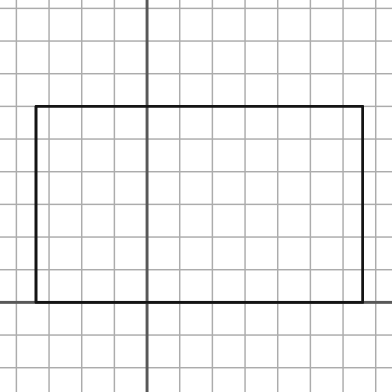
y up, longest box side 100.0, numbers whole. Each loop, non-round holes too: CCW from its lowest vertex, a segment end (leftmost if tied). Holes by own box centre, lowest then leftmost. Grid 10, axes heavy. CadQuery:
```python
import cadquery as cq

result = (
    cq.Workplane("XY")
    .moveTo(-34.0, 0.0)
    .lineTo(66.0, 0.0)
    .lineTo(66.0, 60.0)
    .lineTo(-34.0, 60.0)
    .close()
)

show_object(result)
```